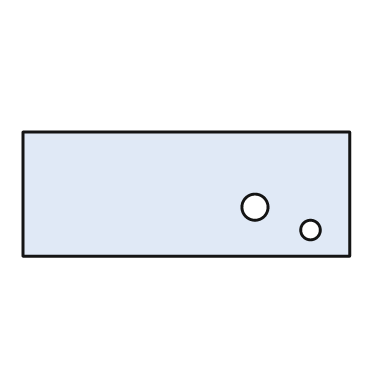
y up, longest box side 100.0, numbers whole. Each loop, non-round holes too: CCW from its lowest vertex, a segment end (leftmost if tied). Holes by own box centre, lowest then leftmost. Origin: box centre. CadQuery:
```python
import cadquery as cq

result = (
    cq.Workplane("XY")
    .moveTo(-50.0, -19.0)
    .lineTo(50.0, -19.0)
    .lineTo(50.0, 19.0)
    .lineTo(-50.0, 19.0)
    .close()
    .moveTo(38.0, -11.0)
    .circle(3.0)
    .moveTo(21.0, -4.0)
    .circle(4.0)
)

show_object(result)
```